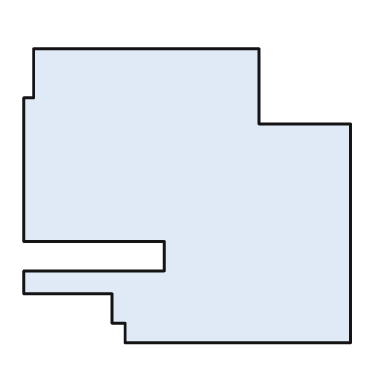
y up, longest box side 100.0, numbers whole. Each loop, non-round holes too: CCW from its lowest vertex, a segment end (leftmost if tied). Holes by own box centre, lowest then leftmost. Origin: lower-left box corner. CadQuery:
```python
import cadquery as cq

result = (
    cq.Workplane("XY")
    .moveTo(31.0, 0.0)
    .lineTo(100.0, 0.0)
    .lineTo(100.0, 67.0)
    .lineTo(72.0, 67.0)
    .lineTo(72.0, 90.0)
    .lineTo(3.0, 90.0)
    .lineTo(3.0, 75.0)
    .lineTo(0.0, 75.0)
    .lineTo(0.0, 31.0)
    .lineTo(43.0, 31.0)
    .lineTo(43.0, 22.0)
    .lineTo(0.0, 22.0)
    .lineTo(0.0, 15.0)
    .lineTo(27.0, 15.0)
    .lineTo(27.0, 6.0)
    .lineTo(31.0, 6.0)
    .close()
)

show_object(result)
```